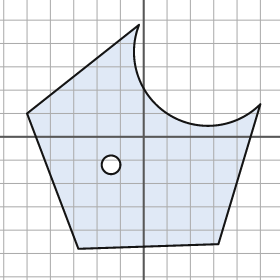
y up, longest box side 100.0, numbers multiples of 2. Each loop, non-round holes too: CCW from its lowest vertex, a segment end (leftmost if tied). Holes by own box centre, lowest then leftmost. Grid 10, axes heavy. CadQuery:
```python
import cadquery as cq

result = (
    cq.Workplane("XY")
    .moveTo(-28.0, -48.0)
    .lineTo(32.0, -46.0)
    .lineTo(50.0, 14.0)
    .threePointArc((10.0, 10.0), (-2.0, 48.0))
    .lineTo(-50.0, 10.0)
    .close()
    .moveTo(-14.0, -12.0)
    .circle(4.0)
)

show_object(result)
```